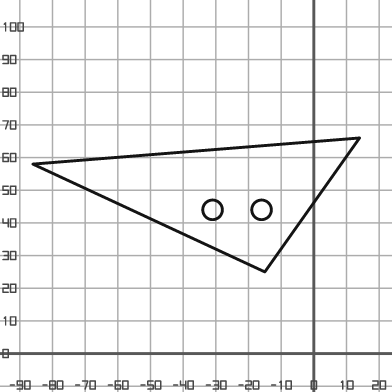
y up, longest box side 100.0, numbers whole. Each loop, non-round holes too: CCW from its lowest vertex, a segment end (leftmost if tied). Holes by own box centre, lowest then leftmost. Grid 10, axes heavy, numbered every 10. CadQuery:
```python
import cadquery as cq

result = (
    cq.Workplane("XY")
    .moveTo(-15.0, 25.0)
    .lineTo(14.0, 66.0)
    .lineTo(-86.0, 58.0)
    .close()
    .moveTo(-31.0, 44.0)
    .circle(3.0)
    .moveTo(-16.0, 44.0)
    .circle(3.0)
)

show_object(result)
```